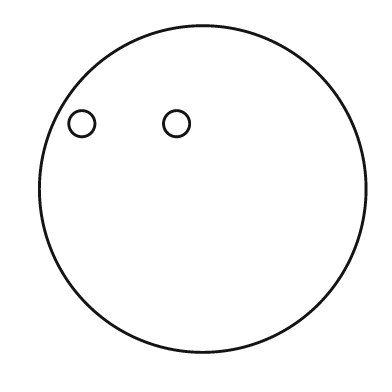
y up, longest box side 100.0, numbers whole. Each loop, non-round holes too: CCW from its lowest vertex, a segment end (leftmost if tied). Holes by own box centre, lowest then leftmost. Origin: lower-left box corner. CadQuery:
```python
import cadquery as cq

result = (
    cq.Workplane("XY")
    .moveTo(50.0, 50.0)
    .circle(50.0)
    .moveTo(13.0, 70.0)
    .circle(4.0)
    .moveTo(42.0, 70.0)
    .circle(4.0)
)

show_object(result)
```